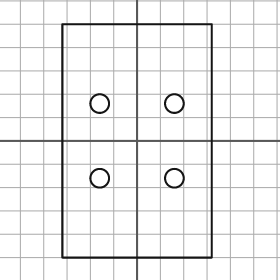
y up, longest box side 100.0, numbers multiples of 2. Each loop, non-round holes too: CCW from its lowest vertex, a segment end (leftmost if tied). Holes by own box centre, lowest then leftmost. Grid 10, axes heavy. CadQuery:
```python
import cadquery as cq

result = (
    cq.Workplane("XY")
    .moveTo(-32.0, -50.0)
    .lineTo(32.0, -50.0)
    .lineTo(32.0, 50.0)
    .lineTo(-32.0, 50.0)
    .close()
    .moveTo(-16.0, -16.0)
    .circle(4.0)
    .moveTo(16.0, -16.0)
    .circle(4.0)
    .moveTo(-16.0, 16.0)
    .circle(4.0)
    .moveTo(16.0, 16.0)
    .circle(4.0)
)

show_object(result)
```